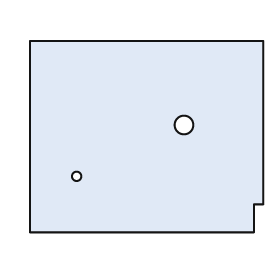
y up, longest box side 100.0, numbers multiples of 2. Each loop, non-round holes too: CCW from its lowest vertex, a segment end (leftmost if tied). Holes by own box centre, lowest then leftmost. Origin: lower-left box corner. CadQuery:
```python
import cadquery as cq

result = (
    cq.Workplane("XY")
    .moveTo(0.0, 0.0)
    .lineTo(96.0, 0.0)
    .lineTo(96.0, 12.0)
    .lineTo(100.0, 12.0)
    .lineTo(100.0, 82.0)
    .lineTo(0.0, 82.0)
    .close()
    .moveTo(20.0, 24.0)
    .circle(2.0)
    .moveTo(66.0, 46.0)
    .circle(4.0)
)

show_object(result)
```